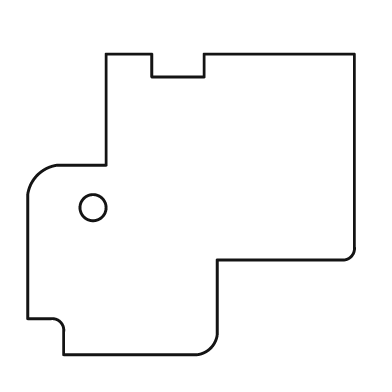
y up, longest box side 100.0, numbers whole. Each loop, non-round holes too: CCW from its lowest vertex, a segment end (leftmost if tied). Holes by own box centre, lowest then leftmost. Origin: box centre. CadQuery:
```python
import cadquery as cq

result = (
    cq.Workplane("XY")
    .moveTo(-39.0, -46.0)
    .lineTo(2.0, -46.0)
    .threePointArc((6.0, -44.0), (8.0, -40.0))
    .lineTo(8.0, -17.0)
    .lineTo(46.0, -17.0)
    .threePointArc((49.0, -16.0), (50.0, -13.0))
    .lineTo(50.0, 46.0)
    .lineTo(4.0, 46.0)
    .lineTo(4.0, 39.0)
    .lineTo(-12.0, 39.0)
    .lineTo(-12.0, 46.0)
    .lineTo(-26.0, 46.0)
    .lineTo(-26.0, 12.0)
    .lineTo(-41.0, 12.0)
    .threePointArc((-47.0, 9.0), (-50.0, 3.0))
    .lineTo(-50.0, -35.0)
    .lineTo(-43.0, -35.0)
    .threePointArc((-40.0, -36.0), (-39.0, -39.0))
    .close()
    .moveTo(-30.0, -1.0)
    .circle(4.0)
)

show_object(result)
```